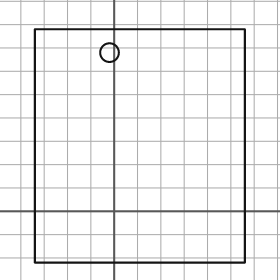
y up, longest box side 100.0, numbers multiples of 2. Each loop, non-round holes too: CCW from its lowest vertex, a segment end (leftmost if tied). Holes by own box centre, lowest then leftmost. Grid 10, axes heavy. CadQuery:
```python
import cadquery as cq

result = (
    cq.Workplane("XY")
    .moveTo(-34.0, -22.0)
    .lineTo(56.0, -22.0)
    .lineTo(56.0, 78.0)
    .lineTo(-34.0, 78.0)
    .close()
    .moveTo(-2.0, 68.0)
    .circle(4.0)
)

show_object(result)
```